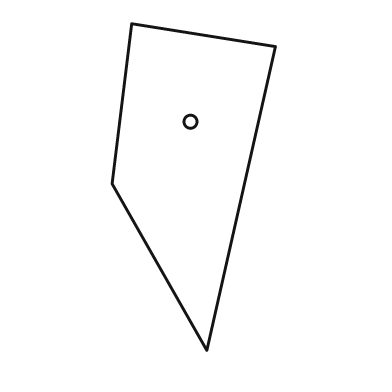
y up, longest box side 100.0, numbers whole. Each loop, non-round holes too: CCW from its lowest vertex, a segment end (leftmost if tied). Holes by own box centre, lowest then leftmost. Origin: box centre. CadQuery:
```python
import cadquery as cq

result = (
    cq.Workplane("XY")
    .moveTo(4.0, -50.0)
    .lineTo(25.0, 43.0)
    .lineTo(-19.0, 50.0)
    .lineTo(-25.0, 1.0)
    .close()
    .moveTo(-1.0, 20.0)
    .circle(2.0)
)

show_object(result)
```